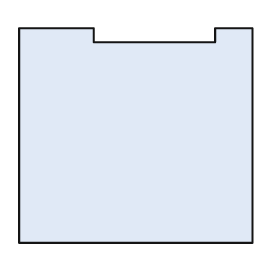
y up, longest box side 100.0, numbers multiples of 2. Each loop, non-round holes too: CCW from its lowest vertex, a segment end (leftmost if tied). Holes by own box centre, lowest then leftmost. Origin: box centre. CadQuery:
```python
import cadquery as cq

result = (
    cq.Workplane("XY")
    .moveTo(-50.0, -46.0)
    .lineTo(50.0, -46.0)
    .lineTo(50.0, 46.0)
    .lineTo(34.0, 46.0)
    .lineTo(34.0, 40.0)
    .lineTo(-18.0, 40.0)
    .lineTo(-18.0, 46.0)
    .lineTo(-50.0, 46.0)
    .close()
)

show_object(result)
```